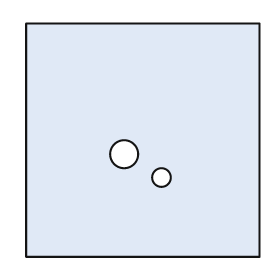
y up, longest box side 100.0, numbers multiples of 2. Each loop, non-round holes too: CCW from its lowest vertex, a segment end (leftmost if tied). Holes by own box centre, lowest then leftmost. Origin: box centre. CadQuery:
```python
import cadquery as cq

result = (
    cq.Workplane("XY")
    .moveTo(-50.0, -50.0)
    .lineTo(50.0, -50.0)
    .lineTo(50.0, 50.0)
    .lineTo(-50.0, 50.0)
    .close()
    .moveTo(8.0, -16.0)
    .circle(4.0)
    .moveTo(-8.0, -6.0)
    .circle(6.0)
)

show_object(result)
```